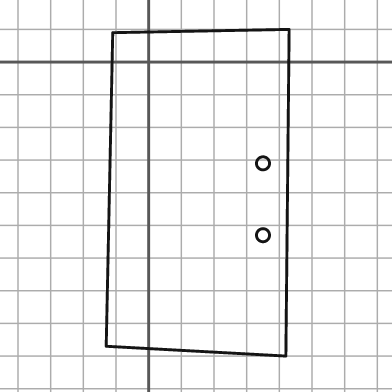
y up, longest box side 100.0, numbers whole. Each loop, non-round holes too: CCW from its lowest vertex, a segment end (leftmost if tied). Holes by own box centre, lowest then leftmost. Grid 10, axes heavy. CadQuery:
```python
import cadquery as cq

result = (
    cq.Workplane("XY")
    .moveTo(42.0, -90.0)
    .lineTo(43.0, 10.0)
    .lineTo(-11.0, 9.0)
    .lineTo(-13.0, -87.0)
    .close()
    .moveTo(35.0, -53.0)
    .circle(2.0)
    .moveTo(35.0, -31.0)
    .circle(2.0)
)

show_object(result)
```